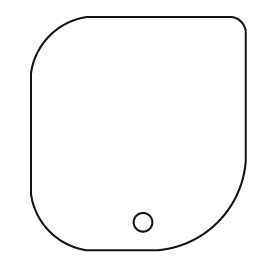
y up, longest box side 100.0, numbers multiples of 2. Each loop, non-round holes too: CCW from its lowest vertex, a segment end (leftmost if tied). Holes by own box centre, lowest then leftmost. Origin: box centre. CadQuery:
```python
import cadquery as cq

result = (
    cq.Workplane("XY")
    .moveTo(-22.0, -50.0)
    .lineTo(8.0, -50.0)
    .threePointArc((34.0, -38.0), (46.0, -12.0))
    .lineTo(46.0, 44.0)
    .threePointArc((44.0, 48.0), (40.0, 50.0))
    .lineTo(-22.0, 50.0)
    .threePointArc((-38.0, 42.0), (-46.0, 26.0))
    .lineTo(-46.0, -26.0)
    .threePointArc((-38.0, -42.0), (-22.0, -50.0))
    .close()
    .moveTo(2.0, -38.0)
    .circle(4.0)
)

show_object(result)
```